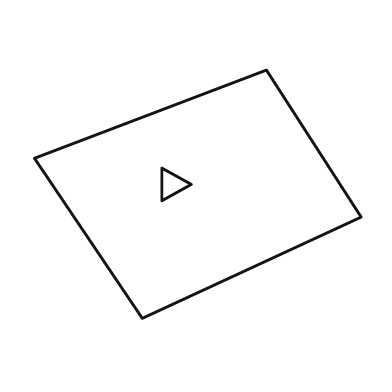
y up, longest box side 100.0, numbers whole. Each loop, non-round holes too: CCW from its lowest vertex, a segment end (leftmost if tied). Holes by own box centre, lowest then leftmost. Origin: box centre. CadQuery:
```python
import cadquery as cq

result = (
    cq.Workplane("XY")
    .moveTo(-17.0, -38.0)
    .lineTo(50.0, -7.0)
    .lineTo(21.0, 38.0)
    .lineTo(-50.0, 11.0)
    .close()
    .moveTo(-11.0, -2.0)
    .lineTo(-2.0, 3.0)
    .lineTo(-11.0, 8.0)
    .close()
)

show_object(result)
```